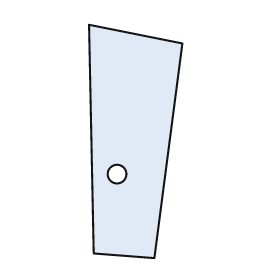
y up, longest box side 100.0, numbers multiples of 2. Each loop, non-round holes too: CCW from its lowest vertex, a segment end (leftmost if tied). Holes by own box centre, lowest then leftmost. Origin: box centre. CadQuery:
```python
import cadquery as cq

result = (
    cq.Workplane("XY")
    .moveTo(8.0, -50.0)
    .lineTo(20.0, 42.0)
    .lineTo(-20.0, 50.0)
    .lineTo(-18.0, -48.0)
    .close()
    .moveTo(-8.0, -14.0)
    .circle(4.0)
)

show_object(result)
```